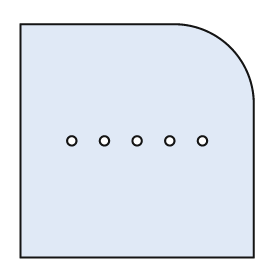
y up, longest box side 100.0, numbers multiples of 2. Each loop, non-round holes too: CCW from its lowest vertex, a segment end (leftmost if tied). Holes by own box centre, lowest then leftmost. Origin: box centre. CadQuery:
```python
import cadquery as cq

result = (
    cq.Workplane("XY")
    .moveTo(-50.0, -50.0)
    .lineTo(50.0, -50.0)
    .lineTo(50.0, 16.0)
    .threePointArc((40.0, 40.0), (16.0, 50.0))
    .lineTo(-50.0, 50.0)
    .close()
    .moveTo(-28.0, 0.0)
    .circle(2.0)
    .moveTo(-14.0, 0.0)
    .circle(2.0)
    .moveTo(0.0, 0.0)
    .circle(2.0)
    .moveTo(14.0, 0.0)
    .circle(2.0)
    .moveTo(28.0, 0.0)
    .circle(2.0)
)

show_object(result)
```